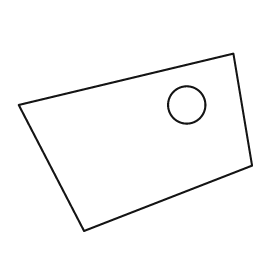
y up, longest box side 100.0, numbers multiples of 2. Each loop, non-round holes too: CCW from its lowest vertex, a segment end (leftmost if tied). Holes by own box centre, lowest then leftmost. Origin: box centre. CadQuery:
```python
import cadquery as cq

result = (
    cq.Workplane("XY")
    .moveTo(-22.0, -38.0)
    .lineTo(50.0, -10.0)
    .lineTo(42.0, 38.0)
    .lineTo(-50.0, 16.0)
    .close()
    .moveTo(22.0, 16.0)
    .circle(8.0)
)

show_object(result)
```